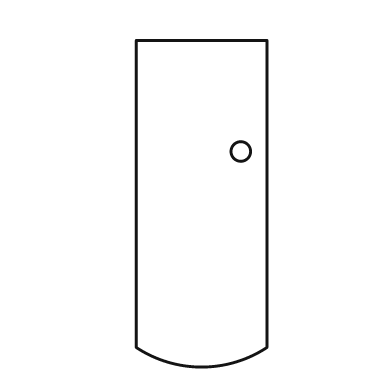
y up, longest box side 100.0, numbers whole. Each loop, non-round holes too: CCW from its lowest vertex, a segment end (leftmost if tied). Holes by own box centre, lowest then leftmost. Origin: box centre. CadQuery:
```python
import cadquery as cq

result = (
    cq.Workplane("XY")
    .moveTo(-20.0, -44.0)
    .threePointArc((0.0, -50.0), (20.0, -44.0))
    .lineTo(20.0, 50.0)
    .lineTo(-20.0, 50.0)
    .close()
    .moveTo(12.0, 16.0)
    .circle(3.0)
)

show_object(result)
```